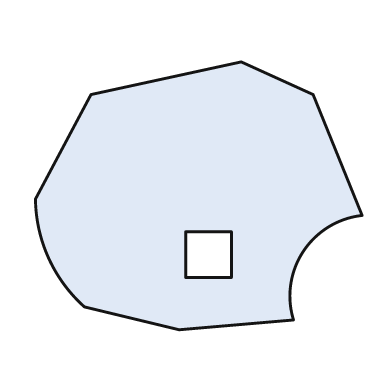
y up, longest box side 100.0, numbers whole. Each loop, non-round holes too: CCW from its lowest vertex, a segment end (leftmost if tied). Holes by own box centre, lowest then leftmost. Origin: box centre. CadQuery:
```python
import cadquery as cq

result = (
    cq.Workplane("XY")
    .moveTo(-6.0, -41.0)
    .lineTo(29.0, -38.0)
    .threePointArc((32.0, -17.0), (50.0, -6.0))
    .lineTo(35.0, 31.0)
    .lineTo(13.0, 41.0)
    .lineTo(-33.0, 31.0)
    .lineTo(-50.0, -1.0)
    .threePointArc((-46.0, -19.0), (-35.0, -34.0))
    .close()
    .moveTo(-4.0, -25.0)
    .lineTo(10.0, -25.0)
    .lineTo(10.0, -11.0)
    .lineTo(-4.0, -11.0)
    .close()
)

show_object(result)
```